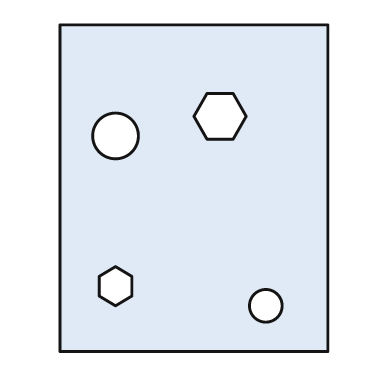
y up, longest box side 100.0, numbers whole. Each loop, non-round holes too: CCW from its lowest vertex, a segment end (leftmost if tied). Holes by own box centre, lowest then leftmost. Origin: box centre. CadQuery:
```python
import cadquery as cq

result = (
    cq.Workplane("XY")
    .moveTo(-41.0, -50.0)
    .lineTo(41.0, -50.0)
    .lineTo(41.0, 50.0)
    .lineTo(-41.0, 50.0)
    .close()
    .moveTo(22.0, -36.0)
    .circle(5.0)
    .moveTo(-24.0, -36.0)
    .lineTo(-19.0, -33.0)
    .lineTo(-19.0, -27.0)
    .lineTo(-24.0, -24.0)
    .lineTo(-29.0, -27.0)
    .lineTo(-29.0, -33.0)
    .close()
    .moveTo(-24.0, 16.0)
    .circle(7.0)
    .moveTo(4.0, 15.0)
    .lineTo(12.0, 15.0)
    .lineTo(16.0, 22.0)
    .lineTo(12.0, 29.0)
    .lineTo(4.0, 29.0)
    .lineTo(0.0, 22.0)
    .close()
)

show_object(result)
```